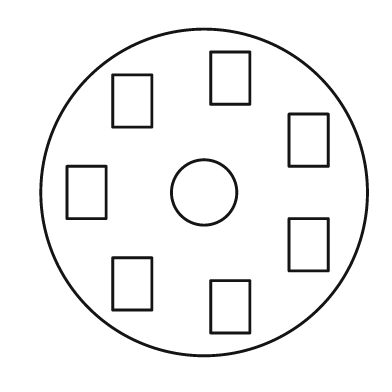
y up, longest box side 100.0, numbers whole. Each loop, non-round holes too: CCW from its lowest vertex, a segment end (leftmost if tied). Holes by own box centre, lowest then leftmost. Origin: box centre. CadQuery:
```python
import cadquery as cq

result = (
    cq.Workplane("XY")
    .moveTo(0.0, 0.0)
    .circle(50.0)
    .moveTo(2.0, -43.0)
    .lineTo(14.0, -43.0)
    .lineTo(14.0, -27.0)
    .lineTo(2.0, -27.0)
    .close()
    .moveTo(-28.0, -36.0)
    .lineTo(-16.0, -36.0)
    .lineTo(-16.0, -20.0)
    .lineTo(-28.0, -20.0)
    .close()
    .moveTo(26.0, -24.0)
    .lineTo(38.0, -24.0)
    .lineTo(38.0, -8.0)
    .lineTo(26.0, -8.0)
    .close()
    .moveTo(-42.0, -8.0)
    .lineTo(-30.0, -8.0)
    .lineTo(-30.0, 8.0)
    .lineTo(-42.0, 8.0)
    .close()
    .moveTo(0.0, 0.0)
    .circle(10.0)
    .moveTo(26.0, 8.0)
    .lineTo(38.0, 8.0)
    .lineTo(38.0, 24.0)
    .lineTo(26.0, 24.0)
    .close()
    .moveTo(-28.0, 20.0)
    .lineTo(-16.0, 20.0)
    .lineTo(-16.0, 36.0)
    .lineTo(-28.0, 36.0)
    .close()
    .moveTo(2.0, 27.0)
    .lineTo(14.0, 27.0)
    .lineTo(14.0, 43.0)
    .lineTo(2.0, 43.0)
    .close()
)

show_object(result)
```